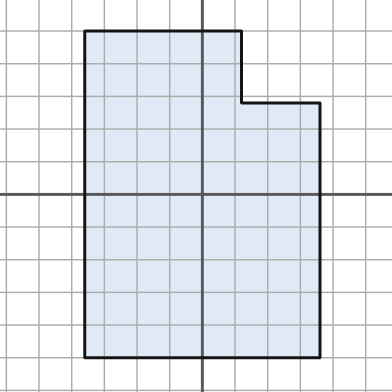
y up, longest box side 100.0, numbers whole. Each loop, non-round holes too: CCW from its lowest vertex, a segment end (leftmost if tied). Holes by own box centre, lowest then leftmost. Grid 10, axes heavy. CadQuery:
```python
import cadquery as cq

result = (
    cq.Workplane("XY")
    .moveTo(-36.0, -50.0)
    .lineTo(36.0, -50.0)
    .lineTo(36.0, 28.0)
    .lineTo(12.0, 28.0)
    .lineTo(12.0, 50.0)
    .lineTo(-36.0, 50.0)
    .close()
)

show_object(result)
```